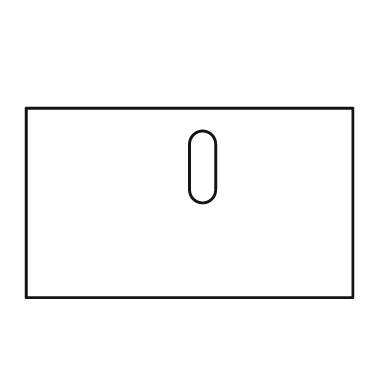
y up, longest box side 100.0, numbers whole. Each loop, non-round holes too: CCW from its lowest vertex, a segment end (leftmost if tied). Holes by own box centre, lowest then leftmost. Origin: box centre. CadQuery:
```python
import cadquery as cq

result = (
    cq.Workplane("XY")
    .moveTo(-50.0, -29.0)
    .lineTo(50.0, -29.0)
    .lineTo(50.0, 29.0)
    .lineTo(-50.0, 29.0)
    .close()
    .moveTo(0.0, 4.0)
    .threePointArc((4.0, 0.0), (8.0, 4.0))
    .lineTo(8.0, 18.0)
    .threePointArc((4.0, 22.0), (0.0, 18.0))
    .close()
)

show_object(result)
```